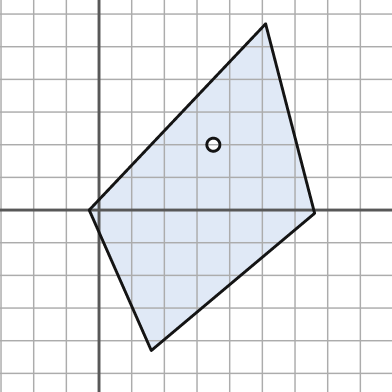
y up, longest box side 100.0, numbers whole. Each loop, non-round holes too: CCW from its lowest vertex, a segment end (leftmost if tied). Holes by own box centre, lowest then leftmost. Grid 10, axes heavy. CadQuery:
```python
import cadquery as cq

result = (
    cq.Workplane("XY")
    .moveTo(16.0, -43.0)
    .lineTo(66.0, -1.0)
    .lineTo(51.0, 57.0)
    .lineTo(-3.0, 0.0)
    .close()
    .moveTo(35.0, 20.0)
    .circle(2.0)
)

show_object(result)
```